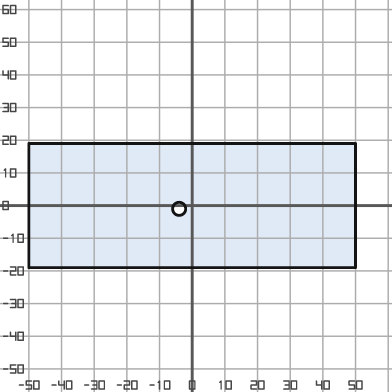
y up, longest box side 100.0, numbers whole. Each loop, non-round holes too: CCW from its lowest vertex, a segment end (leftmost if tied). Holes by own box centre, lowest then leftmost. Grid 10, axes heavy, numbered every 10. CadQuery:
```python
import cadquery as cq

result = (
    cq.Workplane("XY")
    .moveTo(-50.0, -19.0)
    .lineTo(50.0, -19.0)
    .lineTo(50.0, 19.0)
    .lineTo(-50.0, 19.0)
    .close()
    .moveTo(-4.0, -1.0)
    .circle(2.0)
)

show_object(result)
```